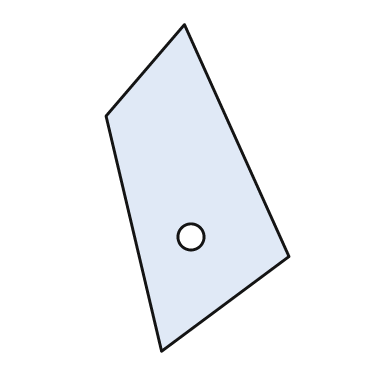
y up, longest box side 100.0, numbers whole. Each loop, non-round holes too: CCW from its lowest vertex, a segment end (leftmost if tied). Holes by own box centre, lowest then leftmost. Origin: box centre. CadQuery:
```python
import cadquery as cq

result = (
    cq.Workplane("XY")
    .moveTo(-11.0, -50.0)
    .lineTo(28.0, -21.0)
    .lineTo(-4.0, 50.0)
    .lineTo(-28.0, 22.0)
    .close()
    .moveTo(-2.0, -15.0)
    .circle(4.0)
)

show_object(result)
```